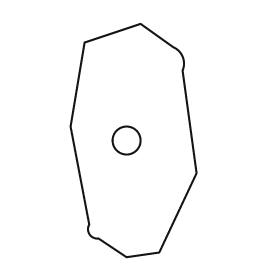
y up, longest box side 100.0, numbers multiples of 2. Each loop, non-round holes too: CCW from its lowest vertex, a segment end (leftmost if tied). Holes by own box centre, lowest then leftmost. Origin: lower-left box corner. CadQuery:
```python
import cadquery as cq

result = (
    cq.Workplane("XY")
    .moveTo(24.0, 0.0)
    .lineTo(38.0, 2.0)
    .lineTo(54.0, 36.0)
    .lineTo(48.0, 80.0)
    .threePointArc((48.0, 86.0), (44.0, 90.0))
    .lineTo(30.0, 100.0)
    .lineTo(6.0, 92.0)
    .lineTo(0.0, 56.0)
    .lineTo(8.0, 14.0)
    .threePointArc((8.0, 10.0), (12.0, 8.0))
    .close()
    .moveTo(24.0, 50.0)
    .circle(6.0)
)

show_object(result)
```